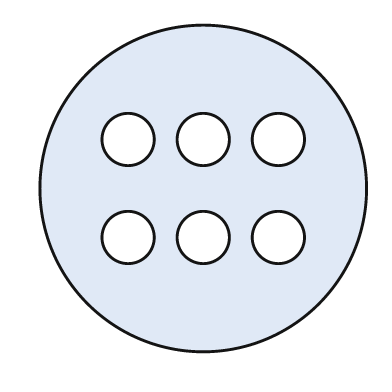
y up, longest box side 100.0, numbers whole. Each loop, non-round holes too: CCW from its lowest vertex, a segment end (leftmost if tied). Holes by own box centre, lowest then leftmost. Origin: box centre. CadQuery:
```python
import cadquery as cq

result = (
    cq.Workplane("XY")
    .moveTo(0.0, 0.0)
    .circle(50.0)
    .moveTo(-23.0, -15.0)
    .circle(8.0)
    .moveTo(0.0, -15.0)
    .circle(8.0)
    .moveTo(23.0, -15.0)
    .circle(8.0)
    .moveTo(-23.0, 15.0)
    .circle(8.0)
    .moveTo(0.0, 15.0)
    .circle(8.0)
    .moveTo(23.0, 15.0)
    .circle(8.0)
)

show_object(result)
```